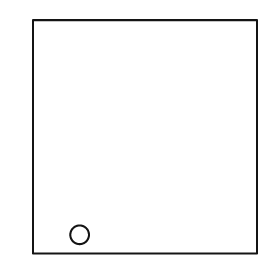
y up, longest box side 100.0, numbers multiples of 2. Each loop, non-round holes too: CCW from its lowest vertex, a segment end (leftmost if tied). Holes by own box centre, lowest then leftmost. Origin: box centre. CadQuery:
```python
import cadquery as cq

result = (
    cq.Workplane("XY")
    .moveTo(-48.0, -50.0)
    .lineTo(48.0, -50.0)
    .lineTo(48.0, 50.0)
    .lineTo(-48.0, 50.0)
    .close()
    .moveTo(-28.0, -42.0)
    .circle(4.0)
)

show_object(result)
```